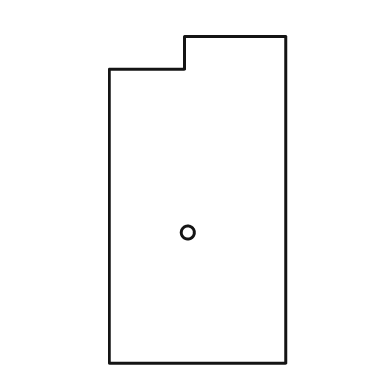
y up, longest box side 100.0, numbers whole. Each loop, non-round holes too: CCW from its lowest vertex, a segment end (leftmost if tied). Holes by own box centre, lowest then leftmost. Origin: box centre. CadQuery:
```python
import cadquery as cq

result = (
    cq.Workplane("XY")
    .moveTo(-27.0, -50.0)
    .lineTo(27.0, -50.0)
    .lineTo(27.0, 50.0)
    .lineTo(-4.0, 50.0)
    .lineTo(-4.0, 40.0)
    .lineTo(-27.0, 40.0)
    .close()
    .moveTo(-3.0, -10.0)
    .circle(2.0)
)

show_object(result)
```